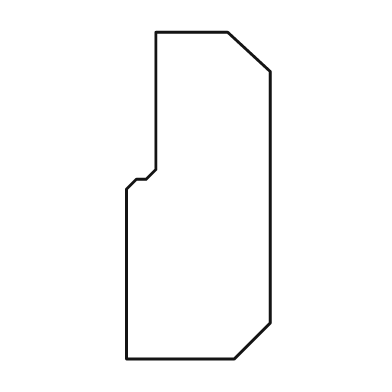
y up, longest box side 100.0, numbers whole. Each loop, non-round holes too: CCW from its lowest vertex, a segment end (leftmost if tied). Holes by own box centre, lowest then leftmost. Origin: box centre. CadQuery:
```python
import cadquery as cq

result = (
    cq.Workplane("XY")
    .moveTo(-22.0, -50.0)
    .lineTo(11.0, -50.0)
    .lineTo(22.0, -39.0)
    .lineTo(22.0, 38.0)
    .lineTo(9.0, 50.0)
    .lineTo(-13.0, 50.0)
    .lineTo(-13.0, 8.0)
    .lineTo(-16.0, 5.0)
    .lineTo(-19.0, 5.0)
    .lineTo(-22.0, 2.0)
    .close()
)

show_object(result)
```